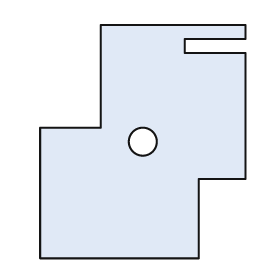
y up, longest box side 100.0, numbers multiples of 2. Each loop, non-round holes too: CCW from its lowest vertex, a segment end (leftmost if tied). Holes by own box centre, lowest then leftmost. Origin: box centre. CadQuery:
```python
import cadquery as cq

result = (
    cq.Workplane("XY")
    .moveTo(-44.0, -50.0)
    .lineTo(24.0, -50.0)
    .lineTo(24.0, -16.0)
    .lineTo(44.0, -16.0)
    .lineTo(44.0, 38.0)
    .lineTo(18.0, 38.0)
    .lineTo(18.0, 44.0)
    .lineTo(44.0, 44.0)
    .lineTo(44.0, 50.0)
    .lineTo(-18.0, 50.0)
    .lineTo(-18.0, 6.0)
    .lineTo(-44.0, 6.0)
    .close()
    .moveTo(0.0, 0.0)
    .circle(6.0)
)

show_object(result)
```